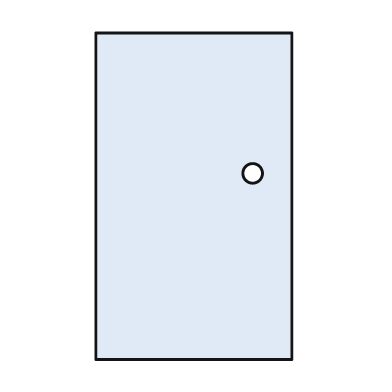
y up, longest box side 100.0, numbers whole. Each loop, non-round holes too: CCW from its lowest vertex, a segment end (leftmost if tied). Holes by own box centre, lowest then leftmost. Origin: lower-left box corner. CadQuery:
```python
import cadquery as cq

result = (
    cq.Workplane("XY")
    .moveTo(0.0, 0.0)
    .lineTo(60.0, 0.0)
    .lineTo(60.0, 100.0)
    .lineTo(0.0, 100.0)
    .close()
    .moveTo(48.0, 57.0)
    .circle(3.0)
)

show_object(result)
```